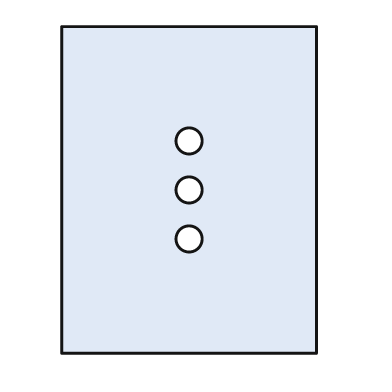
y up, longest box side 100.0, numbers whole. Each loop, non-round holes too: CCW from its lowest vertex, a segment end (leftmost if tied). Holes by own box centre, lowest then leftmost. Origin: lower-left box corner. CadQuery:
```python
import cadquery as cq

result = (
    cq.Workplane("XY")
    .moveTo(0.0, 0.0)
    .lineTo(78.0, 0.0)
    .lineTo(78.0, 100.0)
    .lineTo(0.0, 100.0)
    .close()
    .moveTo(39.0, 35.0)
    .circle(4.0)
    .moveTo(39.0, 50.0)
    .circle(4.0)
    .moveTo(39.0, 65.0)
    .circle(4.0)
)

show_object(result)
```